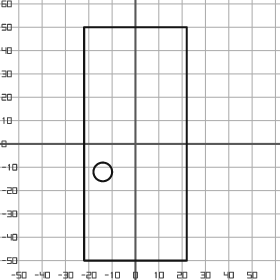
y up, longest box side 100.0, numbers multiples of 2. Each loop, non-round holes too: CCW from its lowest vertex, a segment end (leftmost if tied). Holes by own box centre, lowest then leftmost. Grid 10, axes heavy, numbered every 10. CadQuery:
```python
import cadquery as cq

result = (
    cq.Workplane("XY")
    .moveTo(-22.0, -50.0)
    .lineTo(22.0, -50.0)
    .lineTo(22.0, 50.0)
    .lineTo(-22.0, 50.0)
    .close()
    .moveTo(-14.0, -12.0)
    .circle(4.0)
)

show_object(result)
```